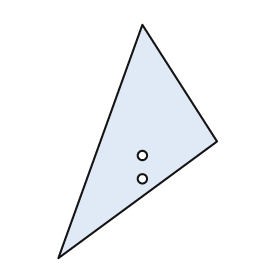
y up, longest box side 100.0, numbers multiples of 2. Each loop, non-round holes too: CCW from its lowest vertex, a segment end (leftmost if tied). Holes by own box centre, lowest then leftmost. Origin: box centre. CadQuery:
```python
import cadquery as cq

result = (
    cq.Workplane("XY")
    .moveTo(-34.0, -50.0)
    .lineTo(34.0, 0.0)
    .lineTo(2.0, 50.0)
    .close()
    .moveTo(2.0, -16.0)
    .circle(2.0)
    .moveTo(2.0, -6.0)
    .circle(2.0)
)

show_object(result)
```